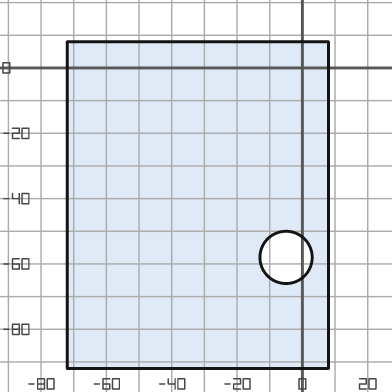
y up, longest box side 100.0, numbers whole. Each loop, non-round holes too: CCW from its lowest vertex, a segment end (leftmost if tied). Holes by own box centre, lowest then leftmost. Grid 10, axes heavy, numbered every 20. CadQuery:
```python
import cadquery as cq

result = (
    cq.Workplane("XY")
    .moveTo(-72.0, -92.0)
    .lineTo(8.0, -92.0)
    .lineTo(8.0, 8.0)
    .lineTo(-72.0, 8.0)
    .close()
    .moveTo(-5.0, -58.0)
    .circle(8.0)
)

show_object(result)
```